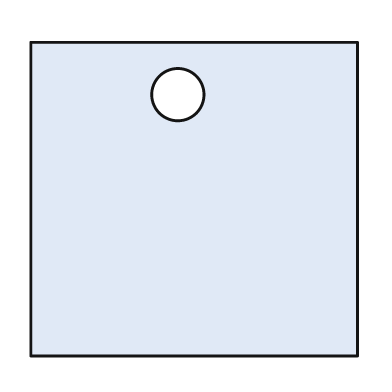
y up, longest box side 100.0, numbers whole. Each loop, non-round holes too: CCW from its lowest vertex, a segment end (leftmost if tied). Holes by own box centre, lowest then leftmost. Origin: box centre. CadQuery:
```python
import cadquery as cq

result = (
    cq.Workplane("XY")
    .moveTo(-50.0, -48.0)
    .lineTo(50.0, -48.0)
    .lineTo(50.0, 48.0)
    .lineTo(-50.0, 48.0)
    .close()
    .moveTo(-5.0, 32.0)
    .circle(8.0)
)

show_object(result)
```